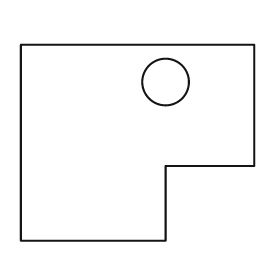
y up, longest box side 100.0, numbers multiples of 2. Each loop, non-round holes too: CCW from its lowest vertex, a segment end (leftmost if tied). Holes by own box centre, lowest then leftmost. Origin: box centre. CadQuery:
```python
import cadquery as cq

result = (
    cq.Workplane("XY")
    .moveTo(-50.0, -42.0)
    .lineTo(12.0, -42.0)
    .lineTo(12.0, -10.0)
    .lineTo(50.0, -10.0)
    .lineTo(50.0, 42.0)
    .lineTo(-50.0, 42.0)
    .close()
    .moveTo(12.0, 26.0)
    .circle(10.0)
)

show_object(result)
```